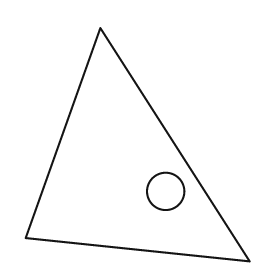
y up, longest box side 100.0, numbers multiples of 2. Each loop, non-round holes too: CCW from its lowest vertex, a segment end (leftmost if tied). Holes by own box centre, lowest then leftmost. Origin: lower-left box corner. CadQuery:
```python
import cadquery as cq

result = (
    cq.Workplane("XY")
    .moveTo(96.0, 0.0)
    .lineTo(32.0, 100.0)
    .lineTo(0.0, 10.0)
    .close()
    .moveTo(60.0, 30.0)
    .circle(8.0)
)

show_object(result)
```